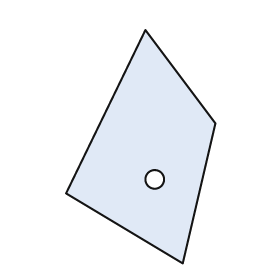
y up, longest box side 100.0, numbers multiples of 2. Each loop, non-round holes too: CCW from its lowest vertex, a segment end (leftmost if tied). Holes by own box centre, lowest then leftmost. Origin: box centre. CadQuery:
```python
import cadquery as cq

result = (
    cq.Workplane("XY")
    .moveTo(18.0, -50.0)
    .lineTo(32.0, 10.0)
    .lineTo(2.0, 50.0)
    .lineTo(-32.0, -20.0)
    .close()
    .moveTo(6.0, -14.0)
    .circle(4.0)
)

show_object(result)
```